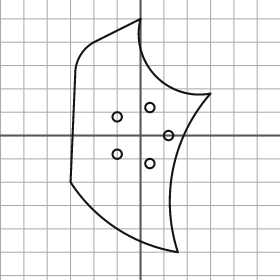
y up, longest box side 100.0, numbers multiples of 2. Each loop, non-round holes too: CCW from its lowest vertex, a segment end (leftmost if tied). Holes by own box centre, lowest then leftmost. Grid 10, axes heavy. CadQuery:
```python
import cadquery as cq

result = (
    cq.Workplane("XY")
    .moveTo(16.0, -50.0)
    .threePointArc((14.0, -14.0), (30.0, 18.0))
    .threePointArc((6.0, 26.0), (0.0, 50.0))
    .lineTo(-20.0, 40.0)
    .threePointArc((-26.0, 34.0), (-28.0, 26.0))
    .lineTo(-30.0, -20.0)
    .threePointArc((-10.0, -40.0), (16.0, -50.0))
    .close()
    .moveTo(4.0, -12.0)
    .circle(2.0)
    .moveTo(-10.0, -8.0)
    .circle(2.0)
    .moveTo(12.0, 0.0)
    .circle(2.0)
    .moveTo(-10.0, 8.0)
    .circle(2.0)
    .moveTo(4.0, 12.0)
    .circle(2.0)
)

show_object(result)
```